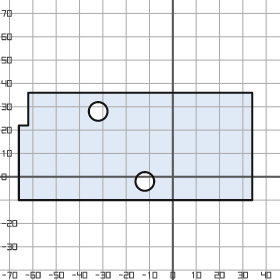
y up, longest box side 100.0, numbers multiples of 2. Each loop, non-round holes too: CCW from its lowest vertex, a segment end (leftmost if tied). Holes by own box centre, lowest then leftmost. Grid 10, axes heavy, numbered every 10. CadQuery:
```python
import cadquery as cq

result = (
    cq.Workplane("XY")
    .moveTo(-66.0, -10.0)
    .lineTo(34.0, -10.0)
    .lineTo(34.0, 36.0)
    .lineTo(-62.0, 36.0)
    .lineTo(-62.0, 22.0)
    .lineTo(-66.0, 22.0)
    .close()
    .moveTo(-12.0, -2.0)
    .circle(4.0)
    .moveTo(-32.0, 28.0)
    .circle(4.0)
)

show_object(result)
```